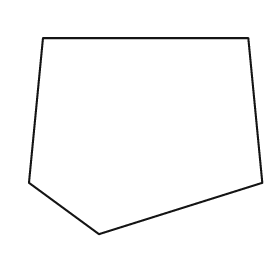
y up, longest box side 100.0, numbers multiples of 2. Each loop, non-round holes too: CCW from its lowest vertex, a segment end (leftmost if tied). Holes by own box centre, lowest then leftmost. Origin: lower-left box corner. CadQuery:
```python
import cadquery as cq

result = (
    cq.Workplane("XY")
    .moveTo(30.0, 0.0)
    .lineTo(100.0, 22.0)
    .lineTo(94.0, 84.0)
    .lineTo(6.0, 84.0)
    .lineTo(0.0, 22.0)
    .close()
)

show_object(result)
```